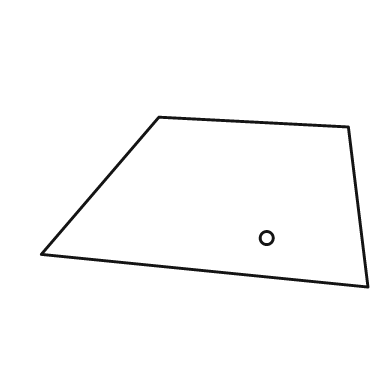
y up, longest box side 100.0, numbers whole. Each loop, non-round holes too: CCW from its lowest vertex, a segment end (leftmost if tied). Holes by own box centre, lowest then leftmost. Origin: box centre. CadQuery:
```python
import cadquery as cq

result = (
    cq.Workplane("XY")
    .moveTo(50.0, -26.0)
    .lineTo(44.0, 23.0)
    .lineTo(-14.0, 26.0)
    .lineTo(-50.0, -16.0)
    .close()
    .moveTo(19.0, -11.0)
    .circle(2.0)
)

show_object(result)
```